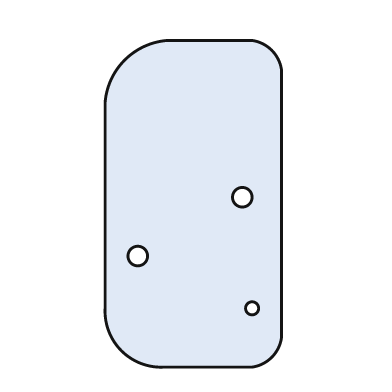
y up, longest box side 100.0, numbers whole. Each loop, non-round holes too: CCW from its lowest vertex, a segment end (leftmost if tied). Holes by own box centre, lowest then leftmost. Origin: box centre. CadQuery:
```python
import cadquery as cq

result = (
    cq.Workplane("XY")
    .moveTo(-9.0, -50.0)
    .lineTo(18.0, -50.0)
    .threePointArc((24.0, -47.0), (27.0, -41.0))
    .lineTo(27.0, 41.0)
    .threePointArc((24.0, 47.0), (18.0, 50.0))
    .lineTo(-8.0, 50.0)
    .threePointArc((-21.0, 44.0), (-27.0, 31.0))
    .lineTo(-27.0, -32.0)
    .threePointArc((-22.0, -45.0), (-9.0, -50.0))
    .close()
    .moveTo(18.0, -32.0)
    .circle(2.0)
    .moveTo(-17.0, -16.0)
    .circle(3.0)
    .moveTo(15.0, 2.0)
    .circle(3.0)
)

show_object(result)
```